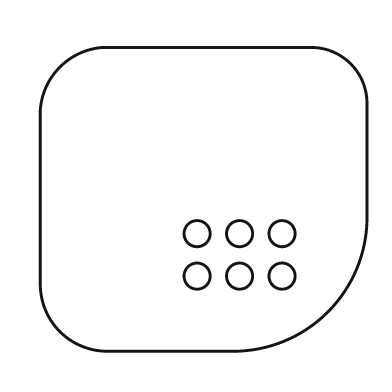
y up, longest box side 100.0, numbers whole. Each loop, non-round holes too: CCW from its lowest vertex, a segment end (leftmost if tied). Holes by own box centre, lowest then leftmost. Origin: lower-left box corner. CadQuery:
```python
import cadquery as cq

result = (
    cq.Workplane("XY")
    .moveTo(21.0, 0.0)
    .lineTo(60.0, 0.0)
    .threePointArc((88.0, 12.0), (100.0, 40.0))
    .lineTo(100.0, 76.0)
    .threePointArc((95.0, 88.0), (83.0, 93.0))
    .lineTo(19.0, 93.0)
    .threePointArc((6.0, 87.0), (0.0, 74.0))
    .lineTo(0.0, 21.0)
    .threePointArc((6.0, 6.0), (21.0, 0.0))
    .close()
    .moveTo(48.0, 23.0)
    .circle(4.0)
    .moveTo(61.0, 23.0)
    .circle(4.0)
    .moveTo(74.0, 23.0)
    .circle(4.0)
    .moveTo(48.0, 36.0)
    .circle(4.0)
    .moveTo(61.0, 36.0)
    .circle(4.0)
    .moveTo(74.0, 36.0)
    .circle(4.0)
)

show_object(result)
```